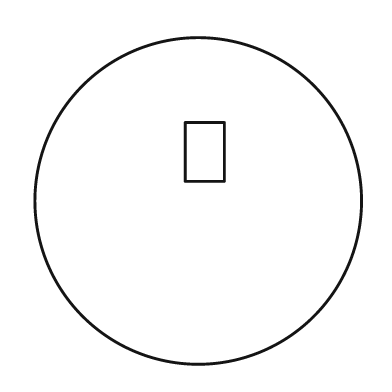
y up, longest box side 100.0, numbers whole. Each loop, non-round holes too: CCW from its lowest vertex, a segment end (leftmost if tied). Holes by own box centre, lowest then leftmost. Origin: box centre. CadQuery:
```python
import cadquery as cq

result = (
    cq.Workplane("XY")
    .moveTo(0.0, 0.0)
    .circle(50.0)
    .moveTo(-4.0, 6.0)
    .lineTo(8.0, 6.0)
    .lineTo(8.0, 24.0)
    .lineTo(-4.0, 24.0)
    .close()
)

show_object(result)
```